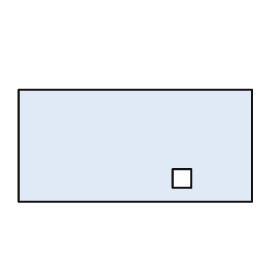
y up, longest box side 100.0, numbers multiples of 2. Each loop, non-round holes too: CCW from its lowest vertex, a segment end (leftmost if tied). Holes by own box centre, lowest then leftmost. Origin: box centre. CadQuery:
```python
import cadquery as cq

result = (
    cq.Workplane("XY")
    .moveTo(-50.0, -24.0)
    .lineTo(50.0, -24.0)
    .lineTo(50.0, 24.0)
    .lineTo(-50.0, 24.0)
    .close()
    .moveTo(16.0, -18.0)
    .lineTo(24.0, -18.0)
    .lineTo(24.0, -10.0)
    .lineTo(16.0, -10.0)
    .close()
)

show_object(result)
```